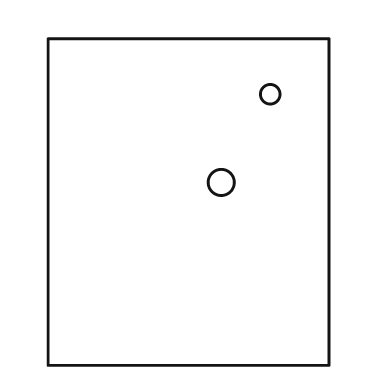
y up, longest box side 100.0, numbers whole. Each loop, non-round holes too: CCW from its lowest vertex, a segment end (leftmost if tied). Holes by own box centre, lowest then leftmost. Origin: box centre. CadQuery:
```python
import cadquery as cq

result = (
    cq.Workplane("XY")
    .moveTo(-43.0, -50.0)
    .lineTo(43.0, -50.0)
    .lineTo(43.0, 50.0)
    .lineTo(-43.0, 50.0)
    .close()
    .moveTo(10.0, 6.0)
    .circle(4.0)
    .moveTo(25.0, 33.0)
    .circle(3.0)
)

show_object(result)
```